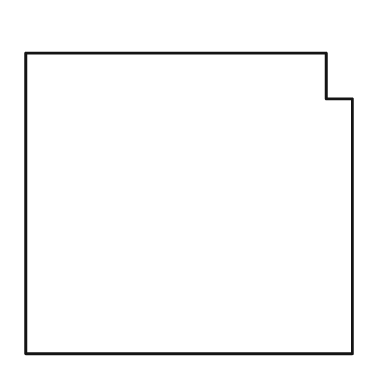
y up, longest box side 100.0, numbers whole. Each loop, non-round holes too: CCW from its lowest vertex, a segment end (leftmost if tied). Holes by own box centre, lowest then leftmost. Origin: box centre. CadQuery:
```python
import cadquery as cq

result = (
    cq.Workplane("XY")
    .moveTo(-50.0, -46.0)
    .lineTo(50.0, -46.0)
    .lineTo(50.0, 32.0)
    .lineTo(42.0, 32.0)
    .lineTo(42.0, 46.0)
    .lineTo(-50.0, 46.0)
    .close()
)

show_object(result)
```